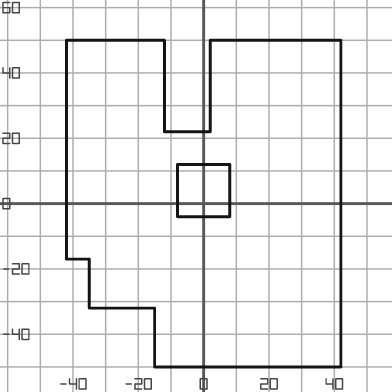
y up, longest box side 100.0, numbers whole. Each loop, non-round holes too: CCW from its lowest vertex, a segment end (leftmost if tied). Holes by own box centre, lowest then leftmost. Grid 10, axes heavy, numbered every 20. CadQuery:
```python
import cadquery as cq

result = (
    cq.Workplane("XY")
    .moveTo(-15.0, -50.0)
    .lineTo(42.0, -50.0)
    .lineTo(42.0, 50.0)
    .lineTo(2.0, 50.0)
    .lineTo(2.0, 22.0)
    .lineTo(-12.0, 22.0)
    .lineTo(-12.0, 50.0)
    .lineTo(-42.0, 50.0)
    .lineTo(-42.0, -17.0)
    .lineTo(-35.0, -17.0)
    .lineTo(-35.0, -32.0)
    .lineTo(-15.0, -32.0)
    .close()
    .moveTo(-8.0, -4.0)
    .lineTo(8.0, -4.0)
    .lineTo(8.0, 12.0)
    .lineTo(-8.0, 12.0)
    .close()
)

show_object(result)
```